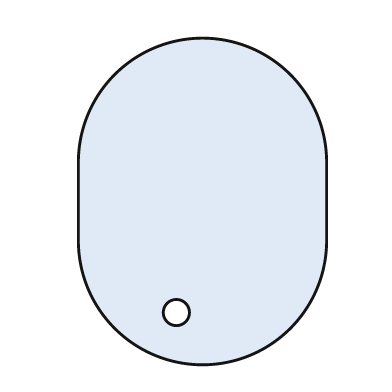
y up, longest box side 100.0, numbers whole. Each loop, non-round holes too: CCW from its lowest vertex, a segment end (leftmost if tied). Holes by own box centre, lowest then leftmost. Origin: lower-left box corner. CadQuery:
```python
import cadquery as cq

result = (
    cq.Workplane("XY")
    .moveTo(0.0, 38.0)
    .threePointArc((38.0, 0.0), (76.0, 38.0))
    .lineTo(76.0, 62.0)
    .threePointArc((38.0, 100.0), (0.0, 62.0))
    .close()
    .moveTo(30.0, 16.0)
    .circle(4.0)
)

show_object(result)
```